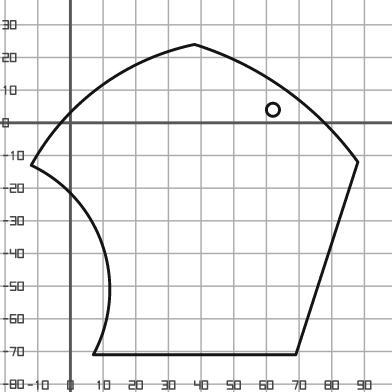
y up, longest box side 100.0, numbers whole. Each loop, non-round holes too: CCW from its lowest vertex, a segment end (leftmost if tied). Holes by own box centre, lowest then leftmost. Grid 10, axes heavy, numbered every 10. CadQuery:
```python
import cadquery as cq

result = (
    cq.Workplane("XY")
    .moveTo(7.0, -71.0)
    .lineTo(69.0, -71.0)
    .lineTo(88.0, -12.0)
    .threePointArc((66.0, 10.0), (38.0, 24.0))
    .threePointArc((9.0, 11.0), (-12.0, -13.0))
    .threePointArc((10.0, -38.0), (7.0, -71.0))
    .close()
    .moveTo(62.0, 4.0)
    .circle(2.0)
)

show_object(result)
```